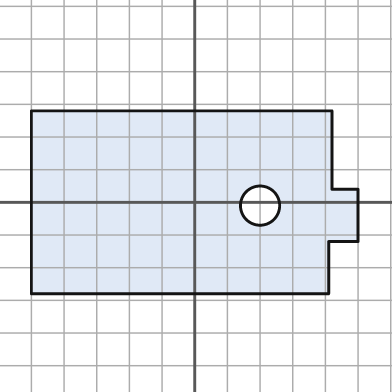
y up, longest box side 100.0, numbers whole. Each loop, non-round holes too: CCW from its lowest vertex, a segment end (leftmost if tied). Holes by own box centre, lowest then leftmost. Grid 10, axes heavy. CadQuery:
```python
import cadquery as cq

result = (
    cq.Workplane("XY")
    .moveTo(-50.0, -28.0)
    .lineTo(41.0, -28.0)
    .lineTo(41.0, -12.0)
    .lineTo(50.0, -12.0)
    .lineTo(50.0, 4.0)
    .lineTo(42.0, 4.0)
    .lineTo(42.0, 28.0)
    .lineTo(-50.0, 28.0)
    .close()
    .moveTo(20.0, -1.0)
    .circle(6.0)
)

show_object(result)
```